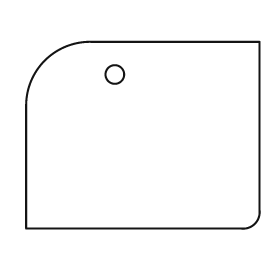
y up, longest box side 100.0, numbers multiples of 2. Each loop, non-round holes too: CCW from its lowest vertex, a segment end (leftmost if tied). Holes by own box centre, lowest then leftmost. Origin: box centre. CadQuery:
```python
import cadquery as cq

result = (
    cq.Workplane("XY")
    .moveTo(-50.0, -40.0)
    .lineTo(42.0, -40.0)
    .threePointArc((48.0, -38.0), (50.0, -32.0))
    .lineTo(50.0, 40.0)
    .lineTo(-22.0, 40.0)
    .threePointArc((-42.0, 32.0), (-50.0, 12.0))
    .close()
    .moveTo(-12.0, 26.0)
    .circle(4.0)
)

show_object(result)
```